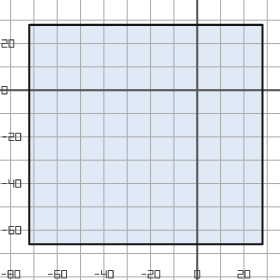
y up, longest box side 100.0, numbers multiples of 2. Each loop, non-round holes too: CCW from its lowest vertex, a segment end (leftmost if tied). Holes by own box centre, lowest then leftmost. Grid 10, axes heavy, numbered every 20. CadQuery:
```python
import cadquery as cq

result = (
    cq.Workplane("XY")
    .moveTo(-72.0, -66.0)
    .lineTo(28.0, -66.0)
    .lineTo(28.0, 28.0)
    .lineTo(-72.0, 28.0)
    .close()
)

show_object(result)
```